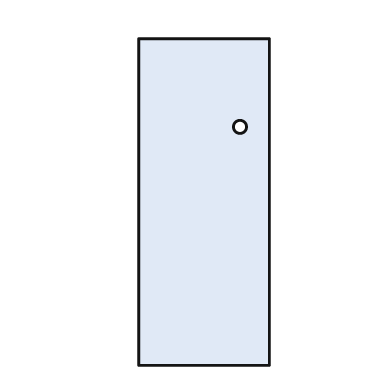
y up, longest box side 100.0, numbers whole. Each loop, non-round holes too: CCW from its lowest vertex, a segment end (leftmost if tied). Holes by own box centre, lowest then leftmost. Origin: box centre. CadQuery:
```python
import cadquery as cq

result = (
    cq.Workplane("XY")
    .moveTo(-20.0, -50.0)
    .lineTo(20.0, -50.0)
    .lineTo(20.0, 50.0)
    .lineTo(-20.0, 50.0)
    .close()
    .moveTo(11.0, 23.0)
    .circle(2.0)
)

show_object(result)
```